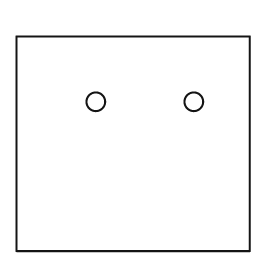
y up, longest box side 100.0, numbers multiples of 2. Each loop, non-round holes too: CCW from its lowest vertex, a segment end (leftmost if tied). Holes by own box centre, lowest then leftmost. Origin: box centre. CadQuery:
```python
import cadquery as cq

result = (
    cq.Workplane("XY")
    .moveTo(-50.0, -46.0)
    .lineTo(50.0, -46.0)
    .lineTo(50.0, 46.0)
    .lineTo(-50.0, 46.0)
    .close()
    .moveTo(-16.0, 18.0)
    .circle(4.0)
    .moveTo(26.0, 18.0)
    .circle(4.0)
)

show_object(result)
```